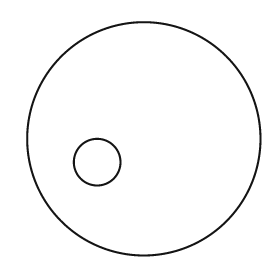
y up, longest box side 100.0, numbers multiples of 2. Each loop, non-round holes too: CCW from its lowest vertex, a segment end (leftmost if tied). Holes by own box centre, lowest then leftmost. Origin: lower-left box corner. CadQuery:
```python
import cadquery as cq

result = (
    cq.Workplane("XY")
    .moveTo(50.0, 50.0)
    .circle(50.0)
    .moveTo(30.0, 40.0)
    .circle(10.0)
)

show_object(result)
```